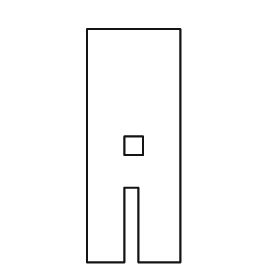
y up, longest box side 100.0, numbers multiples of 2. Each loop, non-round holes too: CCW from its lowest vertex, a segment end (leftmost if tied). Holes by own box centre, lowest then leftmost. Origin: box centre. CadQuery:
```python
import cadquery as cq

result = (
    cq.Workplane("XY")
    .moveTo(-20.0, -50.0)
    .lineTo(-4.0, -50.0)
    .lineTo(-4.0, -18.0)
    .lineTo(2.0, -18.0)
    .lineTo(2.0, -50.0)
    .lineTo(20.0, -50.0)
    .lineTo(20.0, 50.0)
    .lineTo(-20.0, 50.0)
    .close()
    .moveTo(-4.0, -4.0)
    .lineTo(4.0, -4.0)
    .lineTo(4.0, 4.0)
    .lineTo(-4.0, 4.0)
    .close()
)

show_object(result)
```